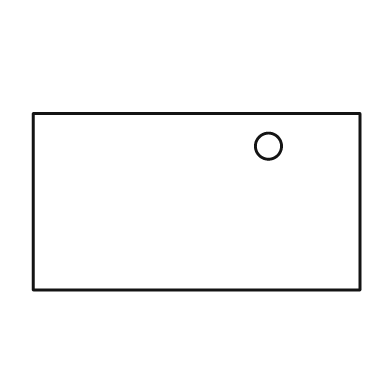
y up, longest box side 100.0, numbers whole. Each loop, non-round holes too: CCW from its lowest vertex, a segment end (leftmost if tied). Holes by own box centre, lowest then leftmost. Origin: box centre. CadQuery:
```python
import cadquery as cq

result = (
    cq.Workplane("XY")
    .moveTo(-50.0, -27.0)
    .lineTo(50.0, -27.0)
    .lineTo(50.0, 27.0)
    .lineTo(-50.0, 27.0)
    .close()
    .moveTo(22.0, 17.0)
    .circle(4.0)
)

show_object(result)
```